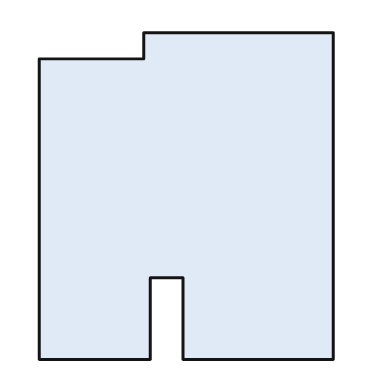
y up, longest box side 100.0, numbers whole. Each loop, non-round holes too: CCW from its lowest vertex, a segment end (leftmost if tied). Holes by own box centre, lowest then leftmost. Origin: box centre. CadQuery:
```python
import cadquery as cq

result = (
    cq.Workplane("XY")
    .moveTo(-45.0, -50.0)
    .lineTo(-11.0, -50.0)
    .lineTo(-11.0, -25.0)
    .lineTo(-1.0, -25.0)
    .lineTo(-1.0, -50.0)
    .lineTo(45.0, -50.0)
    .lineTo(45.0, 50.0)
    .lineTo(-13.0, 50.0)
    .lineTo(-13.0, 42.0)
    .lineTo(-45.0, 42.0)
    .close()
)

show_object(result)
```